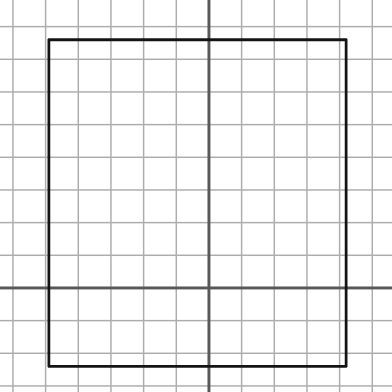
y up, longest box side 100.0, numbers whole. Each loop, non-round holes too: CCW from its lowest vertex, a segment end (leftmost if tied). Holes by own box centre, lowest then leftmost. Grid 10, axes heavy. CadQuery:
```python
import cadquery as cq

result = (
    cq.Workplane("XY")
    .moveTo(-49.0, -24.0)
    .lineTo(42.0, -24.0)
    .lineTo(42.0, 76.0)
    .lineTo(-49.0, 76.0)
    .close()
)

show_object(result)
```